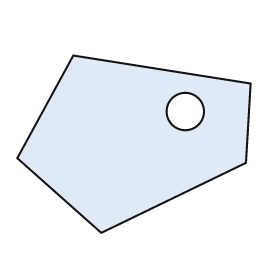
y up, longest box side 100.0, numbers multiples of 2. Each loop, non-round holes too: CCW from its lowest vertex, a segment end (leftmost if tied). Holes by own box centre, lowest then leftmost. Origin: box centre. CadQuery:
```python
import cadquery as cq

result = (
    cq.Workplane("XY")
    .moveTo(-14.0, -38.0)
    .lineTo(48.0, -8.0)
    .lineTo(50.0, 26.0)
    .lineTo(-26.0, 38.0)
    .lineTo(-50.0, -6.0)
    .close()
    .moveTo(22.0, 14.0)
    .circle(8.0)
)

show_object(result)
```